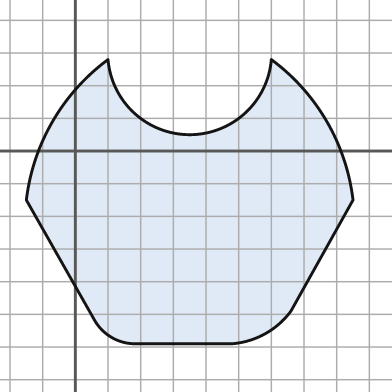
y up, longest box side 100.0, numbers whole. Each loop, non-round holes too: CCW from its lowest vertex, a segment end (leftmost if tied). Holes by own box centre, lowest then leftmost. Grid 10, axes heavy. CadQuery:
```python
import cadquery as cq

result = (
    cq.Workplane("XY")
    .moveTo(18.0, -59.0)
    .lineTo(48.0, -59.0)
    .threePointArc((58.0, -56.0), (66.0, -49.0))
    .lineTo(85.0, -15.0)
    .threePointArc((77.0, 9.0), (60.0, 28.0))
    .threePointArc((35.0, 5.0), (10.0, 28.0))
    .threePointArc((-7.0, 9.0), (-15.0, -15.0))
    .lineTo(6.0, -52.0)
    .threePointArc((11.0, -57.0), (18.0, -59.0))
    .close()
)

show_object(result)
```